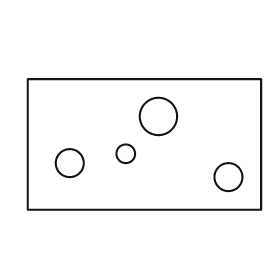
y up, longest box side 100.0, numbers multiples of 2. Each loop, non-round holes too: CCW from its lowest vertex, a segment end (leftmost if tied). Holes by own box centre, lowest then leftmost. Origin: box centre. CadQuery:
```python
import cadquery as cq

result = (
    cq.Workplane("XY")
    .moveTo(-50.0, -28.0)
    .lineTo(50.0, -28.0)
    .lineTo(50.0, 28.0)
    .lineTo(-50.0, 28.0)
    .close()
    .moveTo(36.0, -14.0)
    .circle(6.0)
    .moveTo(-32.0, -8.0)
    .circle(6.0)
    .moveTo(-8.0, -4.0)
    .circle(4.0)
    .moveTo(6.0, 12.0)
    .circle(8.0)
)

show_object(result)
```